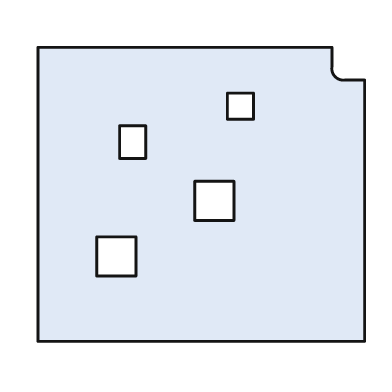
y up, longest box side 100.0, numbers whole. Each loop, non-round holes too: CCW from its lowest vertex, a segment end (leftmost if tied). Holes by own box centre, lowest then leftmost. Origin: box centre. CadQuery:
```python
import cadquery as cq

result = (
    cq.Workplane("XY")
    .moveTo(-50.0, -45.0)
    .lineTo(50.0, -45.0)
    .lineTo(50.0, 35.0)
    .lineTo(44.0, 35.0)
    .threePointArc((41.0, 36.0), (40.0, 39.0))
    .lineTo(40.0, 45.0)
    .lineTo(-50.0, 45.0)
    .close()
    .moveTo(-32.0, -25.0)
    .lineTo(-20.0, -25.0)
    .lineTo(-20.0, -13.0)
    .lineTo(-32.0, -13.0)
    .close()
    .moveTo(-2.0, -8.0)
    .lineTo(10.0, -8.0)
    .lineTo(10.0, 4.0)
    .lineTo(-2.0, 4.0)
    .close()
    .moveTo(-25.0, 11.0)
    .lineTo(-17.0, 11.0)
    .lineTo(-17.0, 21.0)
    .lineTo(-25.0, 21.0)
    .close()
    .moveTo(8.0, 23.0)
    .lineTo(16.0, 23.0)
    .lineTo(16.0, 31.0)
    .lineTo(8.0, 31.0)
    .close()
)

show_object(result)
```